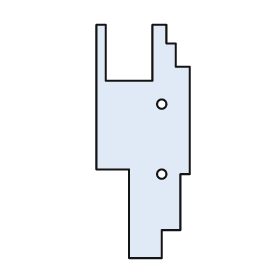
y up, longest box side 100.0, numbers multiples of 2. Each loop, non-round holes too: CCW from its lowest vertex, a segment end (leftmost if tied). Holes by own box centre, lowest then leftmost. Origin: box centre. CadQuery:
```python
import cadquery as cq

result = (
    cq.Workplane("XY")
    .moveTo(-6.0, -50.0)
    .lineTo(8.0, -50.0)
    .lineTo(8.0, -38.0)
    .lineTo(16.0, -38.0)
    .lineTo(16.0, -14.0)
    .lineTo(20.0, -14.0)
    .lineTo(20.0, 32.0)
    .lineTo(14.0, 32.0)
    .lineTo(14.0, 42.0)
    .lineTo(10.0, 42.0)
    .lineTo(10.0, 50.0)
    .lineTo(4.0, 50.0)
    .lineTo(4.0, 26.0)
    .lineTo(-16.0, 26.0)
    .lineTo(-16.0, 50.0)
    .lineTo(-20.0, 50.0)
    .lineTo(-20.0, -12.0)
    .lineTo(-6.0, -12.0)
    .close()
    .moveTo(8.0, -14.0)
    .circle(2.0)
    .moveTo(8.0, 16.0)
    .circle(2.0)
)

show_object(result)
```